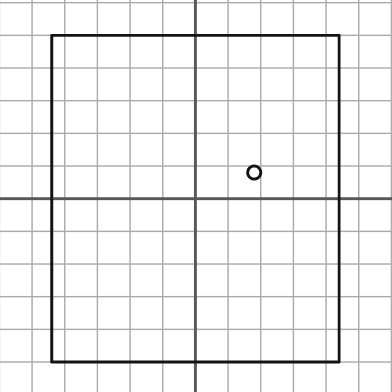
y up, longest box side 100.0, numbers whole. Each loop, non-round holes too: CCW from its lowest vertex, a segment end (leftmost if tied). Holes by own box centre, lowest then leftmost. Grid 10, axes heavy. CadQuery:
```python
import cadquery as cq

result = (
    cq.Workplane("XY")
    .moveTo(-44.0, -50.0)
    .lineTo(44.0, -50.0)
    .lineTo(44.0, 50.0)
    .lineTo(-44.0, 50.0)
    .close()
    .moveTo(18.0, 8.0)
    .circle(2.0)
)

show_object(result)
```